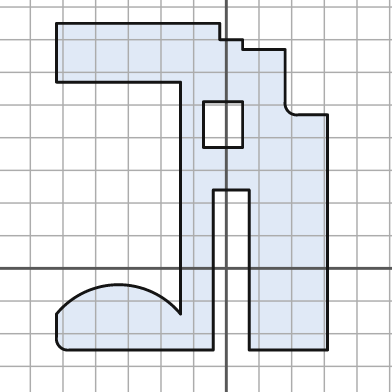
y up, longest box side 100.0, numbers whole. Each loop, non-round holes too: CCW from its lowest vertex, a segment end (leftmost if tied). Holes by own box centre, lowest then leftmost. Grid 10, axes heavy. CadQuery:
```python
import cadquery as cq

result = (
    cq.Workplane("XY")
    .moveTo(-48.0, -25.0)
    .lineTo(-4.0, -25.0)
    .lineTo(-4.0, 24.0)
    .lineTo(7.0, 24.0)
    .lineTo(7.0, -25.0)
    .lineTo(31.0, -25.0)
    .lineTo(31.0, 47.0)
    .lineTo(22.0, 47.0)
    .threePointArc((19.0, 48.0), (18.0, 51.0))
    .lineTo(18.0, 67.0)
    .lineTo(5.0, 67.0)
    .lineTo(5.0, 70.0)
    .lineTo(-2.0, 70.0)
    .lineTo(-2.0, 75.0)
    .lineTo(-52.0, 75.0)
    .lineTo(-52.0, 57.0)
    .lineTo(-14.0, 57.0)
    .lineTo(-14.0, -14.0)
    .threePointArc((-33.0, -5.0), (-52.0, -14.0))
    .lineTo(-52.0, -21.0)
    .threePointArc((-51.0, -24.0), (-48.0, -25.0))
    .close()
    .moveTo(-7.0, 37.0)
    .lineTo(5.0, 37.0)
    .lineTo(5.0, 51.0)
    .lineTo(-7.0, 51.0)
    .close()
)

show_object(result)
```